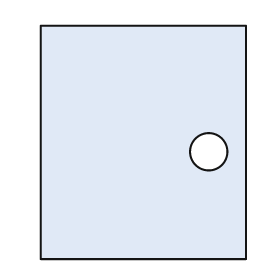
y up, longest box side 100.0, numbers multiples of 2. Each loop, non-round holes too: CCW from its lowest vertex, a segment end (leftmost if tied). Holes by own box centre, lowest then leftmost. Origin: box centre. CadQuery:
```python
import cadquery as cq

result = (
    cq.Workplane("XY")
    .moveTo(-44.0, -50.0)
    .lineTo(44.0, -50.0)
    .lineTo(44.0, 50.0)
    .lineTo(-44.0, 50.0)
    .close()
    .moveTo(28.0, -4.0)
    .circle(8.0)
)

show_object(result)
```